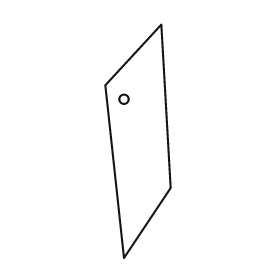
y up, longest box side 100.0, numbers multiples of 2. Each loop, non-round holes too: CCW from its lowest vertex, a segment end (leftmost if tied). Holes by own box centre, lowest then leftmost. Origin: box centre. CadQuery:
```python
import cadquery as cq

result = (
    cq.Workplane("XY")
    .moveTo(-6.0, -50.0)
    .lineTo(14.0, -20.0)
    .lineTo(10.0, 50.0)
    .lineTo(-14.0, 24.0)
    .close()
    .moveTo(-6.0, 18.0)
    .circle(2.0)
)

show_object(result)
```